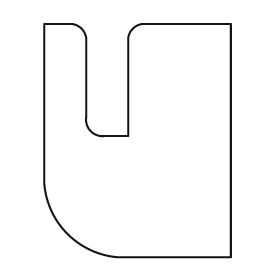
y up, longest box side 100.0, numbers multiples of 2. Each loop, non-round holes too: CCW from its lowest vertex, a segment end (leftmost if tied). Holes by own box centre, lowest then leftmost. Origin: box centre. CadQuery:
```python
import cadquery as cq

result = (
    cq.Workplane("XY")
    .moveTo(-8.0, -50.0)
    .lineTo(40.0, -50.0)
    .lineTo(40.0, 50.0)
    .lineTo(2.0, 50.0)
    .threePointArc((-2.0, 48.0), (-4.0, 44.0))
    .lineTo(-4.0, 2.0)
    .lineTo(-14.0, 2.0)
    .threePointArc((-20.0, 4.0), (-22.0, 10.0))
    .lineTo(-22.0, 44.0)
    .threePointArc((-24.0, 48.0), (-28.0, 50.0))
    .lineTo(-40.0, 50.0)
    .lineTo(-40.0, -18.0)
    .threePointArc((-30.0, -40.0), (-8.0, -50.0))
    .close()
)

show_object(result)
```